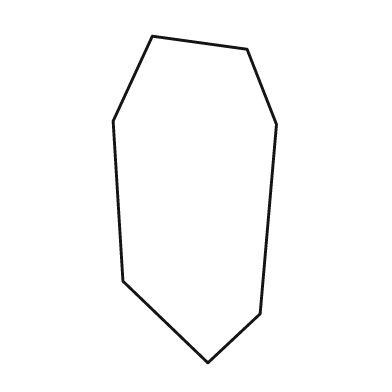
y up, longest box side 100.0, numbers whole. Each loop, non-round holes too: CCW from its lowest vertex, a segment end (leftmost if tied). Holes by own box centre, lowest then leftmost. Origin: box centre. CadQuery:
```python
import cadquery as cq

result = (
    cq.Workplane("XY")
    .moveTo(4.0, -50.0)
    .lineTo(20.0, -35.0)
    .lineTo(25.0, 23.0)
    .lineTo(16.0, 46.0)
    .lineTo(-13.0, 50.0)
    .lineTo(-25.0, 24.0)
    .lineTo(-22.0, -25.0)
    .close()
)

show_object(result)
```